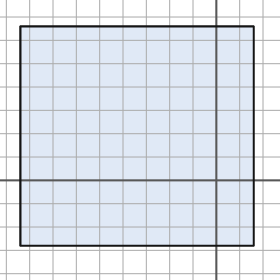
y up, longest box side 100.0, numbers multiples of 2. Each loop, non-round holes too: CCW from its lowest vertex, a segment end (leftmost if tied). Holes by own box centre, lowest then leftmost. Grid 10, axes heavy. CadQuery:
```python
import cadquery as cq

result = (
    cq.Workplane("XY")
    .moveTo(-84.0, -28.0)
    .lineTo(16.0, -28.0)
    .lineTo(16.0, 66.0)
    .lineTo(-84.0, 66.0)
    .close()
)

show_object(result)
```